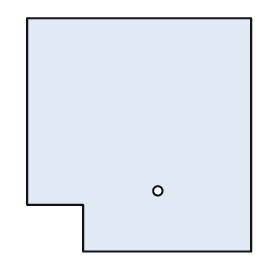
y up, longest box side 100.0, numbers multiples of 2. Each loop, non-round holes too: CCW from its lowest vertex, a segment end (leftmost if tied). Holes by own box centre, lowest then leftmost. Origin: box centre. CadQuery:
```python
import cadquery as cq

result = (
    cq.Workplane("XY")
    .moveTo(-24.0, -50.0)
    .lineTo(48.0, -50.0)
    .lineTo(48.0, 50.0)
    .lineTo(-48.0, 50.0)
    .lineTo(-48.0, -30.0)
    .lineTo(-24.0, -30.0)
    .close()
    .moveTo(8.0, -24.0)
    .circle(2.0)
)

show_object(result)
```